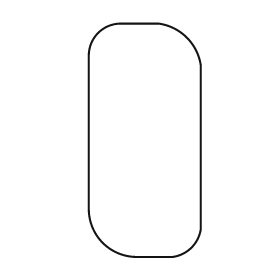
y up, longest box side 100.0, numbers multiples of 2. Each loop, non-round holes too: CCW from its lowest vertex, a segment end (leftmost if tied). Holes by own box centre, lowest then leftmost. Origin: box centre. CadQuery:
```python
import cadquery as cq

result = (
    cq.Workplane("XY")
    .moveTo(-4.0, -50.0)
    .lineTo(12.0, -50.0)
    .threePointArc((20.0, -46.0), (24.0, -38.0))
    .lineTo(24.0, 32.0)
    .threePointArc((18.0, 44.0), (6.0, 50.0))
    .lineTo(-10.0, 50.0)
    .threePointArc((-20.0, 46.0), (-24.0, 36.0))
    .lineTo(-24.0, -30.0)
    .threePointArc((-18.0, -44.0), (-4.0, -50.0))
    .close()
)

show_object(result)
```